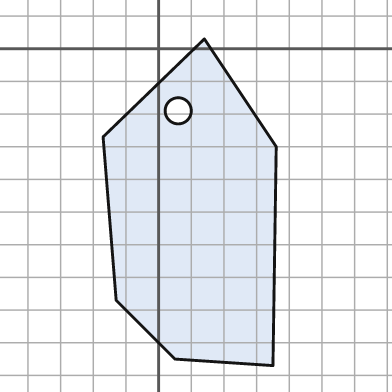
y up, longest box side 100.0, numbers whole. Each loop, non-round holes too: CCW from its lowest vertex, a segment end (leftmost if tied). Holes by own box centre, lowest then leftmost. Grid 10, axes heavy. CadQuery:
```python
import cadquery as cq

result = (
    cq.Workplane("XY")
    .moveTo(35.0, -97.0)
    .lineTo(36.0, -30.0)
    .lineTo(14.0, 3.0)
    .lineTo(-17.0, -27.0)
    .lineTo(-13.0, -77.0)
    .lineTo(5.0, -95.0)
    .close()
    .moveTo(6.0, -19.0)
    .circle(4.0)
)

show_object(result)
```